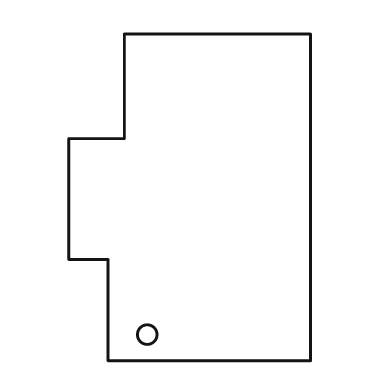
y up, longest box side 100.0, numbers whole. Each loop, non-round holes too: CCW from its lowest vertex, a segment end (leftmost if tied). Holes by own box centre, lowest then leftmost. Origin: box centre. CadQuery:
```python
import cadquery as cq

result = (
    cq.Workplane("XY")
    .moveTo(-25.0, -50.0)
    .lineTo(37.0, -50.0)
    .lineTo(37.0, 50.0)
    .lineTo(-20.0, 50.0)
    .lineTo(-20.0, 18.0)
    .lineTo(-37.0, 18.0)
    .lineTo(-37.0, -19.0)
    .lineTo(-25.0, -19.0)
    .close()
    .moveTo(-13.0, -42.0)
    .circle(3.0)
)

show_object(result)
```